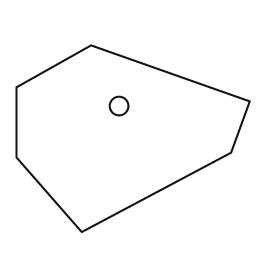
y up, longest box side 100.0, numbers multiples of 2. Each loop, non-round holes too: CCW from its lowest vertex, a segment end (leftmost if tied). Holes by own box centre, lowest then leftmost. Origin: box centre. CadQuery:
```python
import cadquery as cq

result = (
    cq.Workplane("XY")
    .moveTo(-22.0, -40.0)
    .lineTo(42.0, -6.0)
    .lineTo(50.0, 16.0)
    .lineTo(-18.0, 40.0)
    .lineTo(-50.0, 22.0)
    .lineTo(-50.0, -8.0)
    .close()
    .moveTo(-6.0, 14.0)
    .circle(4.0)
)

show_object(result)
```